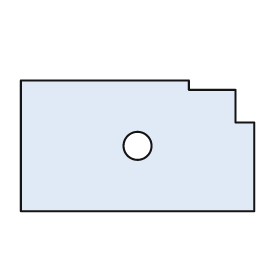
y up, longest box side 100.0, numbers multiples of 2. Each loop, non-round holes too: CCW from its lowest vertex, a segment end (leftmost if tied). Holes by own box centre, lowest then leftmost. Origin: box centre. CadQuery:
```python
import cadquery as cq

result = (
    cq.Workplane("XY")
    .moveTo(-50.0, -28.0)
    .lineTo(50.0, -28.0)
    .lineTo(50.0, 10.0)
    .lineTo(42.0, 10.0)
    .lineTo(42.0, 24.0)
    .lineTo(22.0, 24.0)
    .lineTo(22.0, 28.0)
    .lineTo(-50.0, 28.0)
    .close()
    .moveTo(0.0, 0.0)
    .circle(6.0)
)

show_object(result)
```